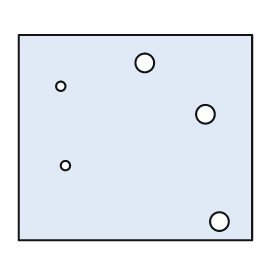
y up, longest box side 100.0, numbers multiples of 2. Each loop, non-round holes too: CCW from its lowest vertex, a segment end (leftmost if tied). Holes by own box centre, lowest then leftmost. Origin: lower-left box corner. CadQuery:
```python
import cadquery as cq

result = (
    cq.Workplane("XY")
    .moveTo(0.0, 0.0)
    .lineTo(100.0, 0.0)
    .lineTo(100.0, 88.0)
    .lineTo(0.0, 88.0)
    .close()
    .moveTo(86.0, 8.0)
    .circle(4.0)
    .moveTo(20.0, 32.0)
    .circle(2.0)
    .moveTo(80.0, 54.0)
    .circle(4.0)
    .moveTo(18.0, 66.0)
    .circle(2.0)
    .moveTo(54.0, 76.0)
    .circle(4.0)
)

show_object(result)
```